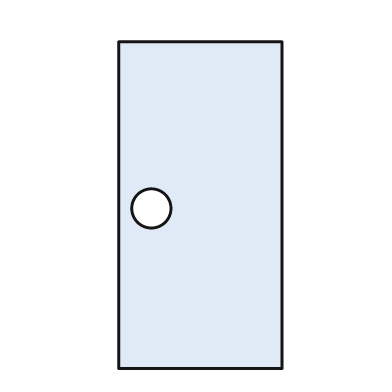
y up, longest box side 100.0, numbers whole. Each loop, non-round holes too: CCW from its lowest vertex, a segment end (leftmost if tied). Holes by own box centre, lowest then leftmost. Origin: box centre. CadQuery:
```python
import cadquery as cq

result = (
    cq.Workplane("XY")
    .moveTo(-25.0, -50.0)
    .lineTo(25.0, -50.0)
    .lineTo(25.0, 50.0)
    .lineTo(-25.0, 50.0)
    .close()
    .moveTo(-15.0, -1.0)
    .circle(6.0)
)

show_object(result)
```